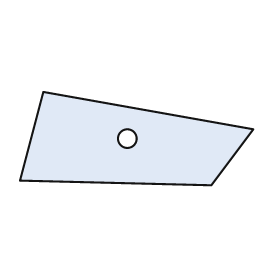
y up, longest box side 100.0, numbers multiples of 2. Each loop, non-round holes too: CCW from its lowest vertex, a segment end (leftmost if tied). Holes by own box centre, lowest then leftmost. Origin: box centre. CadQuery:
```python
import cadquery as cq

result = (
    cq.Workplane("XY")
    .moveTo(32.0, -20.0)
    .lineTo(50.0, 4.0)
    .lineTo(-40.0, 20.0)
    .lineTo(-50.0, -18.0)
    .close()
    .moveTo(-4.0, 0.0)
    .circle(4.0)
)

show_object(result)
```